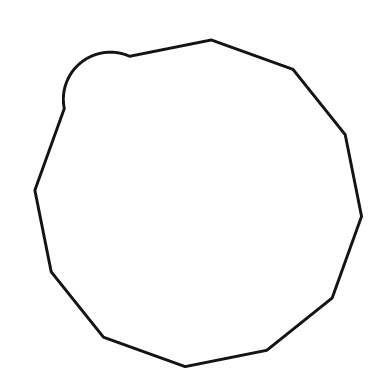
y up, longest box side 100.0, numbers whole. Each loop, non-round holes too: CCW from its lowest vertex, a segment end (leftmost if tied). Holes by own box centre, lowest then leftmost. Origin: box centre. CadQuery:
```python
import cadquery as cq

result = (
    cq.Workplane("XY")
    .moveTo(-4.0, -50.0)
    .lineTo(21.0, -45.0)
    .lineTo(41.0, -29.0)
    .lineTo(50.0, -4.0)
    .lineTo(45.0, 21.0)
    .lineTo(29.0, 41.0)
    .lineTo(4.0, 50.0)
    .lineTo(-21.0, 45.0)
    .threePointArc((-36.0, 43.0), (-41.0, 29.0))
    .lineTo(-50.0, 4.0)
    .lineTo(-45.0, -21.0)
    .lineTo(-29.0, -41.0)
    .close()
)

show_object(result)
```